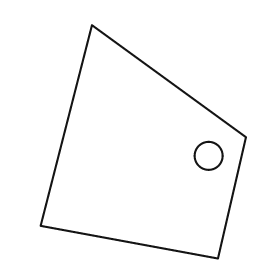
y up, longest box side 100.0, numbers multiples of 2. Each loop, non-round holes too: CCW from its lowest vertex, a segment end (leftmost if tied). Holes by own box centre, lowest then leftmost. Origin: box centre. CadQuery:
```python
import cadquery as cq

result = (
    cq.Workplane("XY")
    .moveTo(32.0, -50.0)
    .lineTo(44.0, 2.0)
    .lineTo(-22.0, 50.0)
    .lineTo(-44.0, -36.0)
    .close()
    .moveTo(28.0, -6.0)
    .circle(6.0)
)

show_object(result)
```